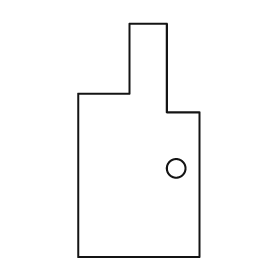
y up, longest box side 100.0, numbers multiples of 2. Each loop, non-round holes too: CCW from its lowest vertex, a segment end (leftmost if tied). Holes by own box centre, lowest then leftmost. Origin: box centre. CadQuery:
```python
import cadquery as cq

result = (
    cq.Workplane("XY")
    .moveTo(-26.0, -50.0)
    .lineTo(26.0, -50.0)
    .lineTo(26.0, 12.0)
    .lineTo(12.0, 12.0)
    .lineTo(12.0, 50.0)
    .lineTo(-4.0, 50.0)
    .lineTo(-4.0, 20.0)
    .lineTo(-26.0, 20.0)
    .close()
    .moveTo(16.0, -12.0)
    .circle(4.0)
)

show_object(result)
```